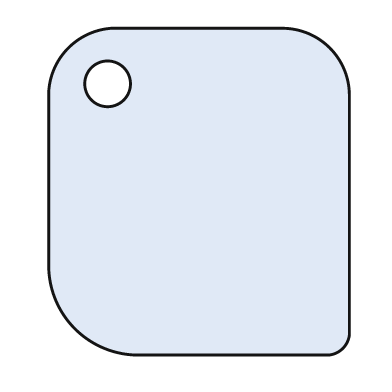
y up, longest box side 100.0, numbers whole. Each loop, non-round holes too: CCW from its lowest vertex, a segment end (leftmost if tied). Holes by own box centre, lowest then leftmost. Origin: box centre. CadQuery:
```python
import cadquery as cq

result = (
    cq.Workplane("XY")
    .moveTo(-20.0, -50.0)
    .lineTo(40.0, -50.0)
    .threePointArc((44.0, -48.0), (46.0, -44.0))
    .lineTo(46.0, 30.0)
    .threePointArc((40.0, 44.0), (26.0, 50.0))
    .lineTo(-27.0, 50.0)
    .threePointArc((-40.0, 44.0), (-46.0, 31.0))
    .lineTo(-46.0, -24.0)
    .threePointArc((-38.0, -42.0), (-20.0, -50.0))
    .close()
    .moveTo(-28.0, 33.0)
    .circle(7.0)
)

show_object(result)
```